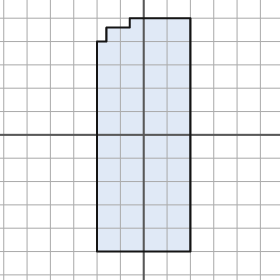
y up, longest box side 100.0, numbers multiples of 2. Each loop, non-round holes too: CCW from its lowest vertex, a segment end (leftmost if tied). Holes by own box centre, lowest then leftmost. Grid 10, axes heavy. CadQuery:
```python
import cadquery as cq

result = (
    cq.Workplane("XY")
    .moveTo(-20.0, -50.0)
    .lineTo(20.0, -50.0)
    .lineTo(20.0, 50.0)
    .lineTo(-6.0, 50.0)
    .lineTo(-6.0, 46.0)
    .lineTo(-16.0, 46.0)
    .lineTo(-16.0, 40.0)
    .lineTo(-20.0, 40.0)
    .close()
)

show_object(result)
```